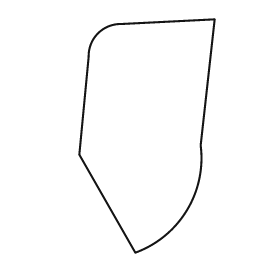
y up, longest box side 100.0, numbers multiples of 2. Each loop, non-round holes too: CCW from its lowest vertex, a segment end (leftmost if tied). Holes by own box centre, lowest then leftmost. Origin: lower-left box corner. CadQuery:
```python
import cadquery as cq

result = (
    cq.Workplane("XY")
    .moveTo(24.0, 0.0)
    .threePointArc((46.0, 18.0), (52.0, 46.0))
    .lineTo(58.0, 100.0)
    .lineTo(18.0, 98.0)
    .threePointArc((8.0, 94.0), (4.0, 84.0))
    .lineTo(0.0, 42.0)
    .close()
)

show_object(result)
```